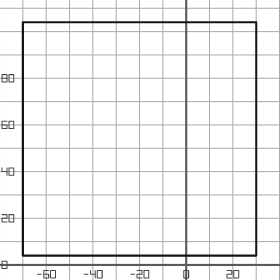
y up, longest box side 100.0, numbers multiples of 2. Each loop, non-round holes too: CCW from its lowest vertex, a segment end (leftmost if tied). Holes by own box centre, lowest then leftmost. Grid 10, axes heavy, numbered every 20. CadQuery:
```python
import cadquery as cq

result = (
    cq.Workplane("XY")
    .moveTo(-70.0, 4.0)
    .lineTo(30.0, 4.0)
    .lineTo(30.0, 104.0)
    .lineTo(-70.0, 104.0)
    .close()
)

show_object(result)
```